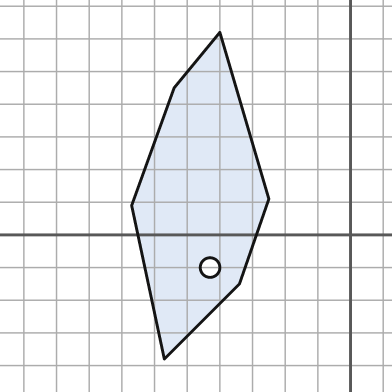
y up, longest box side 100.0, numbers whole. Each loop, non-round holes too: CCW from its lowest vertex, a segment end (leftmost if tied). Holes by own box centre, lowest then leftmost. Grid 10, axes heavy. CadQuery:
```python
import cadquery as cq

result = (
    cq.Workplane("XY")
    .moveTo(-57.0, -38.0)
    .lineTo(-34.0, -15.0)
    .lineTo(-25.0, 11.0)
    .lineTo(-40.0, 62.0)
    .lineTo(-54.0, 45.0)
    .lineTo(-67.0, 9.0)
    .close()
    .moveTo(-43.0, -10.0)
    .circle(3.0)
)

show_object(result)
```